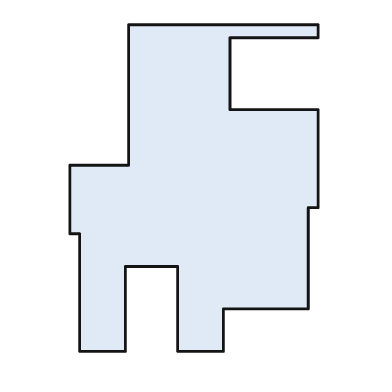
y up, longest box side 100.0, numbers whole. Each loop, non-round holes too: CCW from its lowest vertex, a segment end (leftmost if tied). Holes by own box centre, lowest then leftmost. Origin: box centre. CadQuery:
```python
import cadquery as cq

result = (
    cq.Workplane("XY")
    .moveTo(-35.0, -50.0)
    .lineTo(-21.0, -50.0)
    .lineTo(-21.0, -24.0)
    .lineTo(-5.0, -24.0)
    .lineTo(-5.0, -50.0)
    .lineTo(9.0, -50.0)
    .lineTo(9.0, -37.0)
    .lineTo(35.0, -37.0)
    .lineTo(35.0, -6.0)
    .lineTo(38.0, -6.0)
    .lineTo(38.0, 24.0)
    .lineTo(11.0, 24.0)
    .lineTo(11.0, 46.0)
    .lineTo(38.0, 46.0)
    .lineTo(38.0, 50.0)
    .lineTo(-20.0, 50.0)
    .lineTo(-20.0, 7.0)
    .lineTo(-38.0, 7.0)
    .lineTo(-38.0, -14.0)
    .lineTo(-35.0, -14.0)
    .close()
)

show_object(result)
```